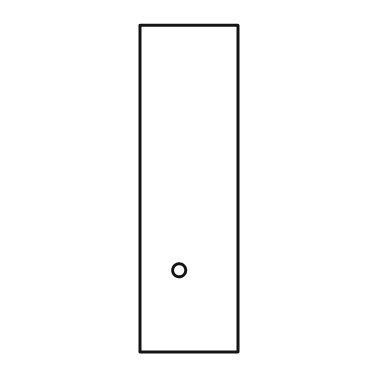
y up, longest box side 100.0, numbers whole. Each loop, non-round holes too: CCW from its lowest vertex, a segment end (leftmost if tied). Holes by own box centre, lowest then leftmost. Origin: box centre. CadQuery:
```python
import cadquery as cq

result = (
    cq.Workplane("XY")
    .moveTo(-15.0, -50.0)
    .lineTo(15.0, -50.0)
    .lineTo(15.0, 50.0)
    .lineTo(-15.0, 50.0)
    .close()
    .moveTo(-3.0, -25.0)
    .circle(2.0)
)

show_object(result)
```